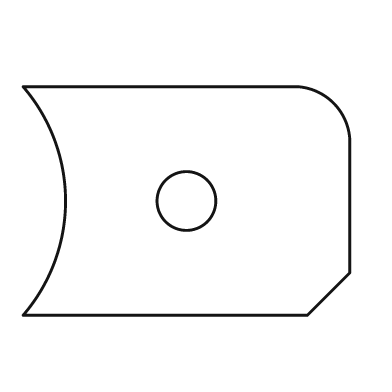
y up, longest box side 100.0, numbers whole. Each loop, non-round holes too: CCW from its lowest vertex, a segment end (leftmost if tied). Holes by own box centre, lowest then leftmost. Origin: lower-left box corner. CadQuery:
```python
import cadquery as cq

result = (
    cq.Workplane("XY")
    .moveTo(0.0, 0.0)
    .lineTo(87.0, 0.0)
    .lineTo(100.0, 13.0)
    .lineTo(100.0, 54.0)
    .threePointArc((95.0, 65.0), (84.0, 70.0))
    .lineTo(0.0, 70.0)
    .threePointArc((13.0, 35.0), (0.0, 0.0))
    .close()
    .moveTo(50.0, 35.0)
    .circle(9.0)
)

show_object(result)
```